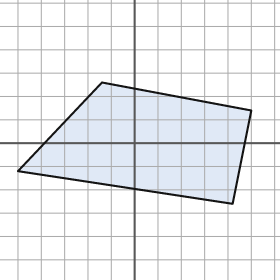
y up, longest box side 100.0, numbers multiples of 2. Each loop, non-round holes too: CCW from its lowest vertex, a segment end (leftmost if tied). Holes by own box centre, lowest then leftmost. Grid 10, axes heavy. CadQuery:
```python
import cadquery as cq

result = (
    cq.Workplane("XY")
    .moveTo(42.0, -26.0)
    .lineTo(50.0, 14.0)
    .lineTo(-14.0, 26.0)
    .lineTo(-50.0, -12.0)
    .close()
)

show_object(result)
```